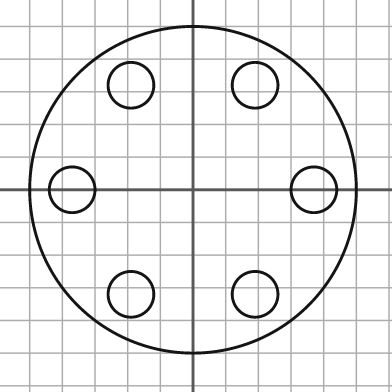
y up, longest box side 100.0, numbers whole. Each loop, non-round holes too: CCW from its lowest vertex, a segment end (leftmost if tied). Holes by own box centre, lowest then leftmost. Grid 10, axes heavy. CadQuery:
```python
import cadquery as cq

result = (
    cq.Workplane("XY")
    .moveTo(0.0, 0.0)
    .circle(50.0)
    .moveTo(-19.0, -32.0)
    .circle(7.0)
    .moveTo(19.0, -32.0)
    .circle(7.0)
    .moveTo(-37.0, 0.0)
    .circle(7.0)
    .moveTo(37.0, 0.0)
    .circle(7.0)
    .moveTo(-19.0, 32.0)
    .circle(7.0)
    .moveTo(19.0, 32.0)
    .circle(7.0)
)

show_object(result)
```